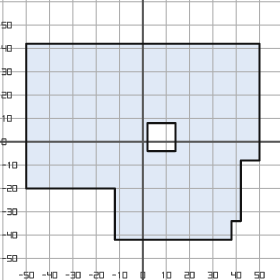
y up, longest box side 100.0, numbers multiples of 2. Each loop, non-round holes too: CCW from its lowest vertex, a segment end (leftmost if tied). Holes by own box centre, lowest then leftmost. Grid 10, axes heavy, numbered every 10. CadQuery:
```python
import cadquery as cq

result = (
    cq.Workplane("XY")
    .moveTo(-12.0, -42.0)
    .lineTo(38.0, -42.0)
    .lineTo(38.0, -34.0)
    .lineTo(42.0, -34.0)
    .lineTo(42.0, -8.0)
    .lineTo(50.0, -8.0)
    .lineTo(50.0, 42.0)
    .lineTo(-50.0, 42.0)
    .lineTo(-50.0, -20.0)
    .lineTo(-12.0, -20.0)
    .close()
    .moveTo(2.0, -4.0)
    .lineTo(14.0, -4.0)
    .lineTo(14.0, 8.0)
    .lineTo(2.0, 8.0)
    .close()
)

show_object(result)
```